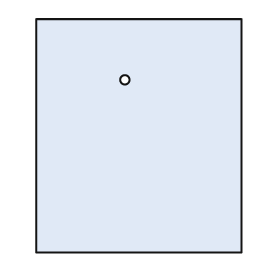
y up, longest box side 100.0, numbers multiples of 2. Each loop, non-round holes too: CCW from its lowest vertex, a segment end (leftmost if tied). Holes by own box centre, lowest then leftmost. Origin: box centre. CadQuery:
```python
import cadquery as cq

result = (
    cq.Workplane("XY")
    .moveTo(-44.0, -50.0)
    .lineTo(44.0, -50.0)
    .lineTo(44.0, 50.0)
    .lineTo(-44.0, 50.0)
    .close()
    .moveTo(-6.0, 24.0)
    .circle(2.0)
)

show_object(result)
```